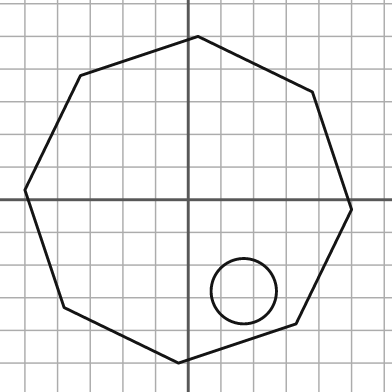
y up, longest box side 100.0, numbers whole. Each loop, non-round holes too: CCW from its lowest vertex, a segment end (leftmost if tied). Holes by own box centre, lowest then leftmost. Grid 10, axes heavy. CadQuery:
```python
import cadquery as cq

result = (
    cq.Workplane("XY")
    .moveTo(-3.0, -50.0)
    .lineTo(33.0, -38.0)
    .lineTo(50.0, -3.0)
    .lineTo(38.0, 33.0)
    .lineTo(3.0, 50.0)
    .lineTo(-33.0, 38.0)
    .lineTo(-50.0, 3.0)
    .lineTo(-38.0, -33.0)
    .close()
    .moveTo(17.0, -28.0)
    .circle(10.0)
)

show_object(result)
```